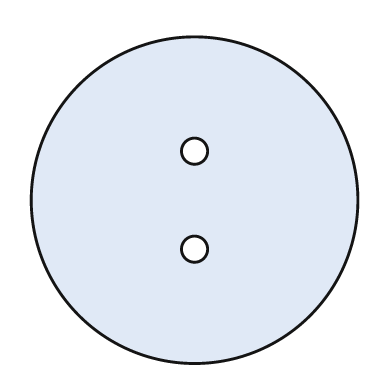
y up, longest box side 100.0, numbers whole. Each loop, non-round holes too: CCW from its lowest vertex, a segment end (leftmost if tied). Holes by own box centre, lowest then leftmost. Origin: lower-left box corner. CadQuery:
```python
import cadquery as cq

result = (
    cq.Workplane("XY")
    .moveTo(50.0, 50.0)
    .circle(50.0)
    .moveTo(50.0, 35.0)
    .circle(4.0)
    .moveTo(50.0, 65.0)
    .circle(4.0)
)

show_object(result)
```